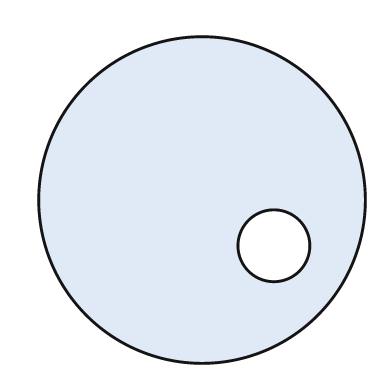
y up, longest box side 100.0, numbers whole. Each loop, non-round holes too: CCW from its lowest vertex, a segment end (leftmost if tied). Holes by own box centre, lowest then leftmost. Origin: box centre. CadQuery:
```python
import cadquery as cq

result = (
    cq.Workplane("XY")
    .moveTo(0.0, 0.0)
    .circle(50.0)
    .moveTo(22.0, -14.0)
    .circle(11.0)
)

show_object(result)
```